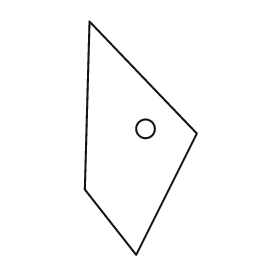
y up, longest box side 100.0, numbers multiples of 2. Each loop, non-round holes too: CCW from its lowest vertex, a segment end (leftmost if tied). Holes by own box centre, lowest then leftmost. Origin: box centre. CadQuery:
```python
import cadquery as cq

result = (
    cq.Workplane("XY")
    .moveTo(-2.0, -50.0)
    .lineTo(24.0, 2.0)
    .lineTo(-22.0, 50.0)
    .lineTo(-24.0, -22.0)
    .close()
    .moveTo(2.0, 4.0)
    .circle(4.0)
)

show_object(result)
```